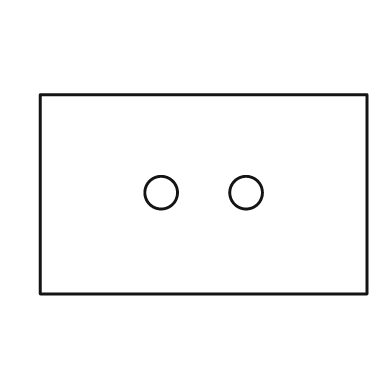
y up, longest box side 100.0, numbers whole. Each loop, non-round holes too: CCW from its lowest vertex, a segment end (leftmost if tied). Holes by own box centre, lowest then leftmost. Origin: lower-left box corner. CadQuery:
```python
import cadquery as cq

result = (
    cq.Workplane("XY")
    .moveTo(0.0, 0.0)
    .lineTo(100.0, 0.0)
    .lineTo(100.0, 61.0)
    .lineTo(0.0, 61.0)
    .close()
    .moveTo(37.0, 31.0)
    .circle(5.0)
    .moveTo(63.0, 31.0)
    .circle(5.0)
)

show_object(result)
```